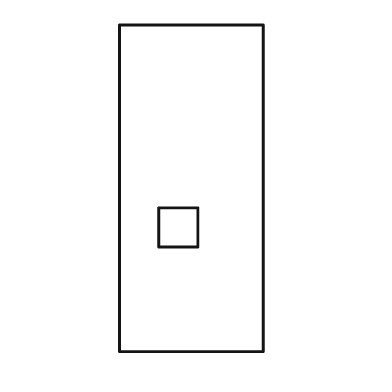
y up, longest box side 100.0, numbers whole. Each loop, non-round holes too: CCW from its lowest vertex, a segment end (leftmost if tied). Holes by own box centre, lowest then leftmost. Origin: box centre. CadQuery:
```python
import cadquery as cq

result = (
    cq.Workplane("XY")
    .moveTo(-22.0, -50.0)
    .lineTo(22.0, -50.0)
    .lineTo(22.0, 50.0)
    .lineTo(-22.0, 50.0)
    .close()
    .moveTo(-10.0, -18.0)
    .lineTo(2.0, -18.0)
    .lineTo(2.0, -6.0)
    .lineTo(-10.0, -6.0)
    .close()
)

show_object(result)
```